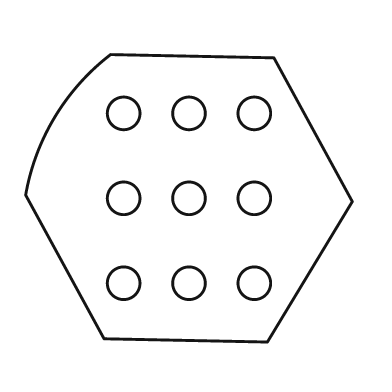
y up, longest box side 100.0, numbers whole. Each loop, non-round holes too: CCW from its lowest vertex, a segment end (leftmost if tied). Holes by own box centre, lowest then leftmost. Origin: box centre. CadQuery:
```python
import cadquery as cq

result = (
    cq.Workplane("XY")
    .moveTo(24.0, -44.0)
    .lineTo(50.0, -1.0)
    .lineTo(26.0, 43.0)
    .lineTo(-24.0, 44.0)
    .threePointArc((-41.0, 25.0), (-50.0, 1.0))
    .lineTo(-26.0, -43.0)
    .close()
    .moveTo(-20.0, -26.0)
    .circle(5.0)
    .moveTo(0.0, -26.0)
    .circle(5.0)
    .moveTo(20.0, -26.0)
    .circle(5.0)
    .moveTo(-20.0, 0.0)
    .circle(5.0)
    .moveTo(0.0, 0.0)
    .circle(5.0)
    .moveTo(20.0, 0.0)
    .circle(5.0)
    .moveTo(-20.0, 26.0)
    .circle(5.0)
    .moveTo(0.0, 26.0)
    .circle(5.0)
    .moveTo(20.0, 26.0)
    .circle(5.0)
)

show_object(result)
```